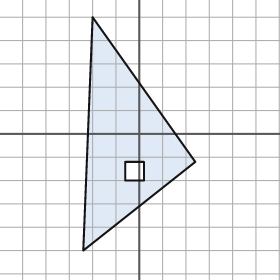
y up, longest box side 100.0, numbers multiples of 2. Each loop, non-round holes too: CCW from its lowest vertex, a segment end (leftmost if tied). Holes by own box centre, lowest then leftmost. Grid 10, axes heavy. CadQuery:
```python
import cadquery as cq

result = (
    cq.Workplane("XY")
    .moveTo(-24.0, -50.0)
    .lineTo(24.0, -12.0)
    .lineTo(-20.0, 50.0)
    .close()
    .moveTo(-6.0, -20.0)
    .lineTo(2.0, -20.0)
    .lineTo(2.0, -12.0)
    .lineTo(-6.0, -12.0)
    .close()
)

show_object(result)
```